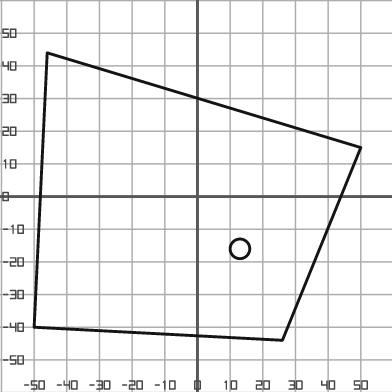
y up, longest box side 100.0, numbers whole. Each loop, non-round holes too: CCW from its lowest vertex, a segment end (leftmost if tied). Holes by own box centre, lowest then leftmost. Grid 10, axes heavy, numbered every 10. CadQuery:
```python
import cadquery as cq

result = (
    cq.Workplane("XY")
    .moveTo(26.0, -44.0)
    .lineTo(50.0, 15.0)
    .lineTo(-46.0, 44.0)
    .lineTo(-50.0, -40.0)
    .close()
    .moveTo(13.0, -16.0)
    .circle(3.0)
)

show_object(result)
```